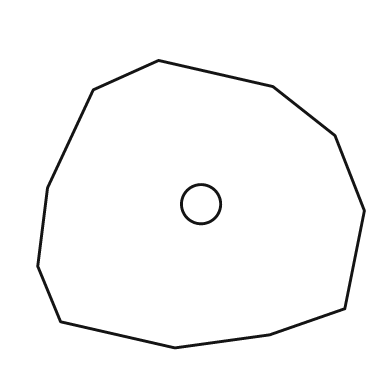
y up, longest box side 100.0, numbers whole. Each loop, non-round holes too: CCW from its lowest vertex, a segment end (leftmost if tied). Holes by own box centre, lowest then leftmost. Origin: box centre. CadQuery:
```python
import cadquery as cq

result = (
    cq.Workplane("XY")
    .moveTo(-8.0, -44.0)
    .lineTo(21.0, -40.0)
    .lineTo(44.0, -32.0)
    .lineTo(50.0, -2.0)
    .lineTo(41.0, 21.0)
    .lineTo(22.0, 36.0)
    .lineTo(-13.0, 44.0)
    .lineTo(-33.0, 35.0)
    .lineTo(-47.0, 5.0)
    .lineTo(-50.0, -19.0)
    .lineTo(-43.0, -36.0)
    .close()
    .moveTo(0.0, 0.0)
    .circle(6.0)
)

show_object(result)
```